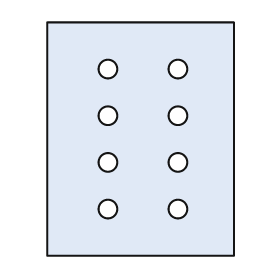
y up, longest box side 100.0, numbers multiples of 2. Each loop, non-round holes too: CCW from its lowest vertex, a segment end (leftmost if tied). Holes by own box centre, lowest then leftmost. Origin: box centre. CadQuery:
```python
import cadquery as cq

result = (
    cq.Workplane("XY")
    .moveTo(-40.0, -50.0)
    .lineTo(40.0, -50.0)
    .lineTo(40.0, 50.0)
    .lineTo(-40.0, 50.0)
    .close()
    .moveTo(-14.0, -30.0)
    .circle(4.0)
    .moveTo(16.0, -30.0)
    .circle(4.0)
    .moveTo(-14.0, -10.0)
    .circle(4.0)
    .moveTo(16.0, -10.0)
    .circle(4.0)
    .moveTo(-14.0, 10.0)
    .circle(4.0)
    .moveTo(16.0, 10.0)
    .circle(4.0)
    .moveTo(-14.0, 30.0)
    .circle(4.0)
    .moveTo(16.0, 30.0)
    .circle(4.0)
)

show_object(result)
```